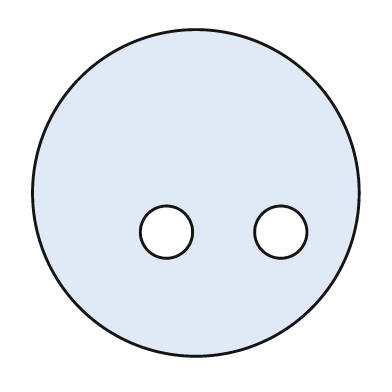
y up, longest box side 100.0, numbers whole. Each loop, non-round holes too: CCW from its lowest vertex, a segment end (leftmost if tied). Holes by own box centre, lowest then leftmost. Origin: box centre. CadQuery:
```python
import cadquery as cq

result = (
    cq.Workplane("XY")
    .moveTo(0.0, 0.0)
    .circle(50.0)
    .moveTo(-9.0, -12.0)
    .circle(8.0)
    .moveTo(26.0, -12.0)
    .circle(8.0)
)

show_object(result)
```